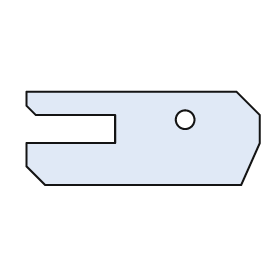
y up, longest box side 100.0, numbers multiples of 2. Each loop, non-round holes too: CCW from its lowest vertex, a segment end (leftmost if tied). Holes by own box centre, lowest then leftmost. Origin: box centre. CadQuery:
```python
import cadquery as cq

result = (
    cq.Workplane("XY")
    .moveTo(-42.0, -20.0)
    .lineTo(42.0, -20.0)
    .lineTo(50.0, -2.0)
    .lineTo(50.0, 10.0)
    .lineTo(40.0, 20.0)
    .lineTo(-50.0, 20.0)
    .lineTo(-50.0, 14.0)
    .lineTo(-46.0, 10.0)
    .lineTo(-12.0, 10.0)
    .lineTo(-12.0, -2.0)
    .lineTo(-50.0, -2.0)
    .lineTo(-50.0, -12.0)
    .close()
    .moveTo(18.0, 8.0)
    .circle(4.0)
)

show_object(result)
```